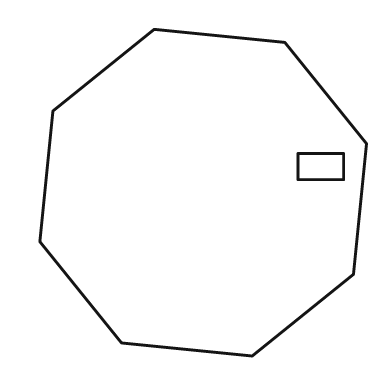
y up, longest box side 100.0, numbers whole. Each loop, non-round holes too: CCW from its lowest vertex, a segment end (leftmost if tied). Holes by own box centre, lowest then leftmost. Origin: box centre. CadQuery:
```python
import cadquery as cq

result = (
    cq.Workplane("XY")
    .moveTo(15.0, -50.0)
    .lineTo(46.0, -25.0)
    .lineTo(50.0, 15.0)
    .lineTo(25.0, 46.0)
    .lineTo(-15.0, 50.0)
    .lineTo(-46.0, 25.0)
    .lineTo(-50.0, -15.0)
    .lineTo(-25.0, -46.0)
    .close()
    .moveTo(29.0, 4.0)
    .lineTo(43.0, 4.0)
    .lineTo(43.0, 12.0)
    .lineTo(29.0, 12.0)
    .close()
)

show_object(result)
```